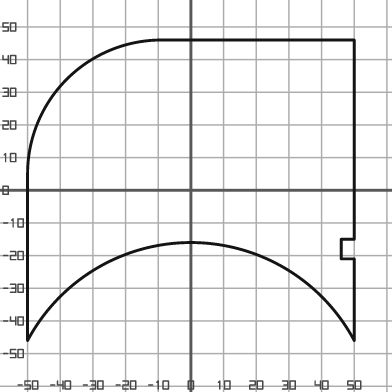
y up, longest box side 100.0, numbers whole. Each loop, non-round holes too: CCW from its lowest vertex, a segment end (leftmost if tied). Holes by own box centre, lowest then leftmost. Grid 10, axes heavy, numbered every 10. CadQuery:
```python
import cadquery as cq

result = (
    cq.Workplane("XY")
    .moveTo(-50.0, -46.0)
    .threePointArc((0.0, -16.0), (50.0, -46.0))
    .lineTo(50.0, -21.0)
    .lineTo(46.0, -21.0)
    .lineTo(46.0, -15.0)
    .lineTo(50.0, -15.0)
    .lineTo(50.0, 46.0)
    .lineTo(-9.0, 46.0)
    .threePointArc((-38.0, 34.0), (-50.0, 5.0))
    .close()
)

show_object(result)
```